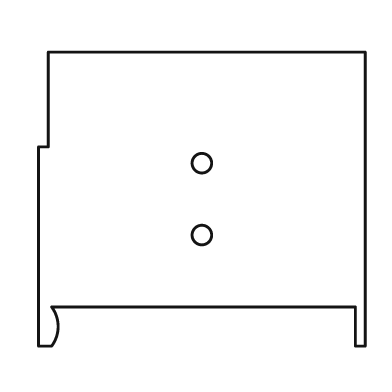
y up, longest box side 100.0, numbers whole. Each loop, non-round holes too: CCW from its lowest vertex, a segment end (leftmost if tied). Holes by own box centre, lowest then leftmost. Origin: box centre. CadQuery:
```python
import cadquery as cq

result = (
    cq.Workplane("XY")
    .moveTo(-50.0, -45.0)
    .lineTo(-46.0, -45.0)
    .threePointArc((-44.0, -39.0), (-46.0, -33.0))
    .lineTo(47.0, -33.0)
    .lineTo(47.0, -45.0)
    .lineTo(50.0, -45.0)
    .lineTo(50.0, 45.0)
    .lineTo(-47.0, 45.0)
    .lineTo(-47.0, 16.0)
    .lineTo(-50.0, 16.0)
    .close()
    .moveTo(0.0, -11.0)
    .circle(3.0)
    .moveTo(0.0, 11.0)
    .circle(3.0)
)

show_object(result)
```